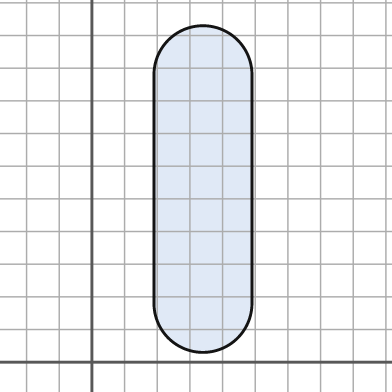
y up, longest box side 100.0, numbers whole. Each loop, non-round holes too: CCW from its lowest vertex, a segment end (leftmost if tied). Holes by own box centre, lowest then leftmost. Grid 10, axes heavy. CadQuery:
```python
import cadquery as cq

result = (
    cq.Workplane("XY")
    .moveTo(19.0, 18.0)
    .threePointArc((34.0, 3.0), (49.0, 18.0))
    .lineTo(49.0, 88.0)
    .threePointArc((34.0, 103.0), (19.0, 88.0))
    .close()
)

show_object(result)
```